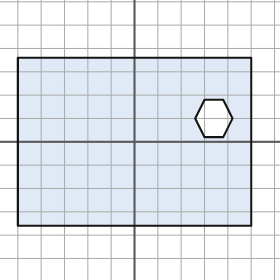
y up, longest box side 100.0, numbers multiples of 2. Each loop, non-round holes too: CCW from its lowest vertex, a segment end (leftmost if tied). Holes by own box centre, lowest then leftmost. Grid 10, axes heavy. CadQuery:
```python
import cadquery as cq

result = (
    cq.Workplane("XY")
    .moveTo(-50.0, -36.0)
    .lineTo(50.0, -36.0)
    .lineTo(50.0, 36.0)
    .lineTo(-50.0, 36.0)
    .close()
    .moveTo(30.0, 2.0)
    .lineTo(38.0, 2.0)
    .lineTo(42.0, 10.0)
    .lineTo(38.0, 18.0)
    .lineTo(30.0, 18.0)
    .lineTo(26.0, 10.0)
    .close()
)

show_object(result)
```